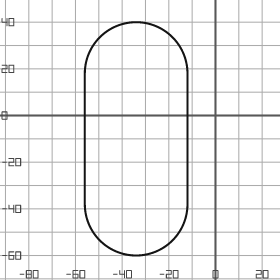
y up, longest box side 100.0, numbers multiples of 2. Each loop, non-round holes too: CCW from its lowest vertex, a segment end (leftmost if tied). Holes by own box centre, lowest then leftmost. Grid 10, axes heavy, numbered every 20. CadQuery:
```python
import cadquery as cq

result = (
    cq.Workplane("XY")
    .moveTo(-56.0, -38.0)
    .threePointArc((-34.0, -60.0), (-12.0, -38.0))
    .lineTo(-12.0, 18.0)
    .threePointArc((-34.0, 40.0), (-56.0, 18.0))
    .close()
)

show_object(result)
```